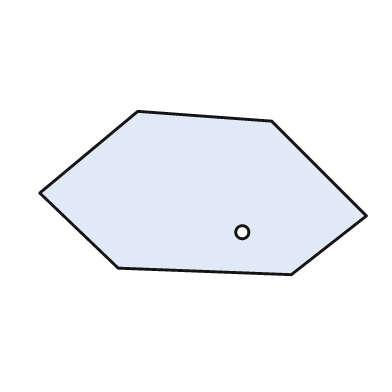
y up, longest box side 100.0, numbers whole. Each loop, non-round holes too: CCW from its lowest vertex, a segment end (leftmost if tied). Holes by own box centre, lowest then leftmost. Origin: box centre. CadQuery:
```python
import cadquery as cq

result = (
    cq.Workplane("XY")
    .moveTo(27.0, -25.0)
    .lineTo(50.0, -7.0)
    .lineTo(21.0, 22.0)
    .lineTo(-20.0, 25.0)
    .lineTo(-50.0, 0.0)
    .lineTo(-26.0, -23.0)
    .close()
    .moveTo(12.0, -12.0)
    .circle(2.0)
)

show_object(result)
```